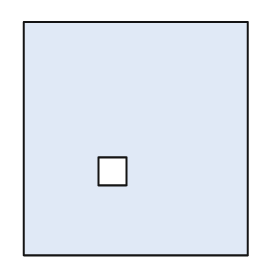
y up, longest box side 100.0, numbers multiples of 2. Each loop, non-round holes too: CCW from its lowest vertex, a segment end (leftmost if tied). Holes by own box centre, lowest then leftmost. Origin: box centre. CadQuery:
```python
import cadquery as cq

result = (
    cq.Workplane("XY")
    .moveTo(-48.0, -50.0)
    .lineTo(48.0, -50.0)
    .lineTo(48.0, 50.0)
    .lineTo(-48.0, 50.0)
    .close()
    .moveTo(-16.0, -20.0)
    .lineTo(-4.0, -20.0)
    .lineTo(-4.0, -8.0)
    .lineTo(-16.0, -8.0)
    .close()
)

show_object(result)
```